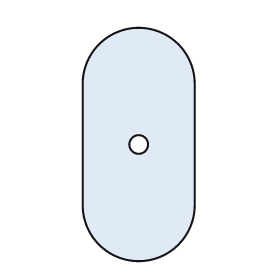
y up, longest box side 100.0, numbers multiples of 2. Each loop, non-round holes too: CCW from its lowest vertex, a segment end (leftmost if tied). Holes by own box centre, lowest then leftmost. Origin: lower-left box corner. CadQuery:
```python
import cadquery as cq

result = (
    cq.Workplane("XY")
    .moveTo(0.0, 24.0)
    .threePointArc((24.0, 0.0), (48.0, 24.0))
    .lineTo(48.0, 76.0)
    .threePointArc((24.0, 100.0), (0.0, 76.0))
    .close()
    .moveTo(24.0, 50.0)
    .circle(4.0)
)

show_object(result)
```